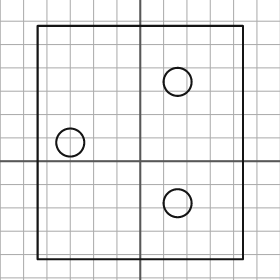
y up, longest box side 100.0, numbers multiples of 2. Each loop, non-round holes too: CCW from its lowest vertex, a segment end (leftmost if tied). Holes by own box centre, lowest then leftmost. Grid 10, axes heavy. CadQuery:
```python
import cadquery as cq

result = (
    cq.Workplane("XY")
    .moveTo(-44.0, -42.0)
    .lineTo(44.0, -42.0)
    .lineTo(44.0, 58.0)
    .lineTo(-44.0, 58.0)
    .close()
    .moveTo(16.0, -18.0)
    .circle(6.0)
    .moveTo(-30.0, 8.0)
    .circle(6.0)
    .moveTo(16.0, 34.0)
    .circle(6.0)
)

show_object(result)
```